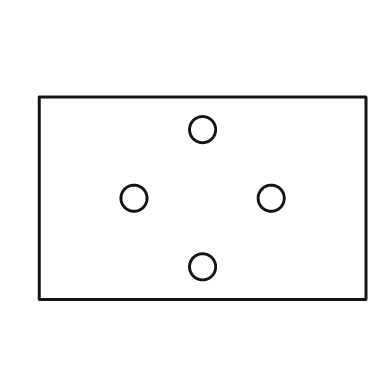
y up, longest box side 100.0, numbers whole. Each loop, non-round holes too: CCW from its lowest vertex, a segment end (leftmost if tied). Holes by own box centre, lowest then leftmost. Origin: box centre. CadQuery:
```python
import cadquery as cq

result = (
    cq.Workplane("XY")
    .moveTo(-50.0, -31.0)
    .lineTo(50.0, -31.0)
    .lineTo(50.0, 31.0)
    .lineTo(-50.0, 31.0)
    .close()
    .moveTo(0.0, -21.0)
    .circle(4.0)
    .moveTo(-21.0, 0.0)
    .circle(4.0)
    .moveTo(21.0, 0.0)
    .circle(4.0)
    .moveTo(0.0, 21.0)
    .circle(4.0)
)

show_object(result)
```